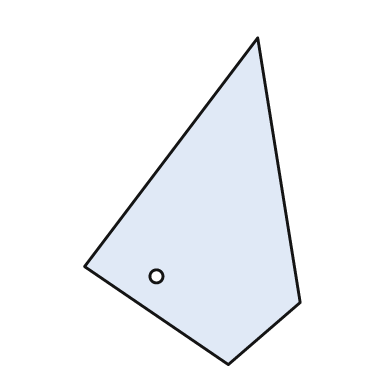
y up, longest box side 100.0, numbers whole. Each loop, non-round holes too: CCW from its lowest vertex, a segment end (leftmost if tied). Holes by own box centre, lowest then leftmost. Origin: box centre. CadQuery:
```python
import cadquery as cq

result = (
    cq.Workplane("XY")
    .moveTo(11.0, -50.0)
    .lineTo(33.0, -31.0)
    .lineTo(20.0, 50.0)
    .lineTo(-33.0, -20.0)
    .close()
    .moveTo(-11.0, -23.0)
    .circle(2.0)
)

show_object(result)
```